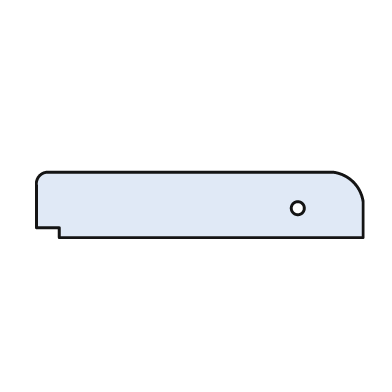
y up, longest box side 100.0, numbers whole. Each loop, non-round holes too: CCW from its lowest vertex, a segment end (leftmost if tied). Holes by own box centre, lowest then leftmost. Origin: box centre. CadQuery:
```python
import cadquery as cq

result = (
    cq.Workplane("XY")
    .moveTo(-43.0, -10.0)
    .lineTo(50.0, -10.0)
    .lineTo(50.0, 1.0)
    .threePointArc((47.0, 7.0), (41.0, 10.0))
    .lineTo(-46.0, 10.0)
    .threePointArc((-49.0, 9.0), (-50.0, 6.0))
    .lineTo(-50.0, -7.0)
    .lineTo(-43.0, -7.0)
    .close()
    .moveTo(30.0, -1.0)
    .circle(2.0)
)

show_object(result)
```